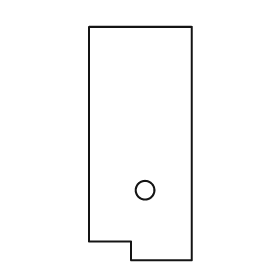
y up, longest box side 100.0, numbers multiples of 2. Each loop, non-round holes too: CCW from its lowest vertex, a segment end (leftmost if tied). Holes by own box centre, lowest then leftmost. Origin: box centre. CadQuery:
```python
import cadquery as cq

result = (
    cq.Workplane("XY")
    .moveTo(-4.0, -50.0)
    .lineTo(22.0, -50.0)
    .lineTo(22.0, 50.0)
    .lineTo(-22.0, 50.0)
    .lineTo(-22.0, -42.0)
    .lineTo(-4.0, -42.0)
    .close()
    .moveTo(2.0, -20.0)
    .circle(4.0)
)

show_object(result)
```